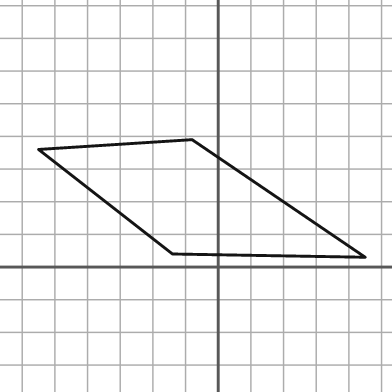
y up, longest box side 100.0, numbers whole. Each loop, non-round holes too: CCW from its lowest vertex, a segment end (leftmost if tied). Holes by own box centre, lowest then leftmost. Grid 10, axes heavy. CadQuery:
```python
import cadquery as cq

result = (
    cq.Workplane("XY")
    .moveTo(45.0, 3.0)
    .lineTo(-8.0, 39.0)
    .lineTo(-55.0, 36.0)
    .lineTo(-14.0, 4.0)
    .close()
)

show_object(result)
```